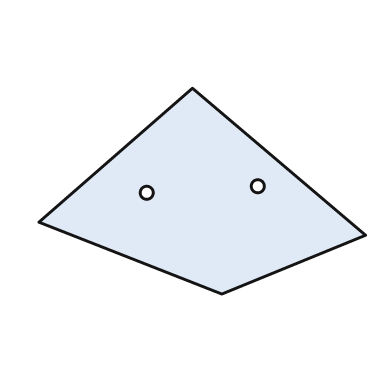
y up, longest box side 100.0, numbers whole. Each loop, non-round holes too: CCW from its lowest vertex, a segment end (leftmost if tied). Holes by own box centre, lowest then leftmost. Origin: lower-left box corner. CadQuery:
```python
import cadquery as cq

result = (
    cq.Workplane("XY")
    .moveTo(56.0, 0.0)
    .lineTo(100.0, 18.0)
    .lineTo(47.0, 63.0)
    .lineTo(0.0, 22.0)
    .close()
    .moveTo(33.0, 31.0)
    .circle(2.0)
    .moveTo(67.0, 33.0)
    .circle(2.0)
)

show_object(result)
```